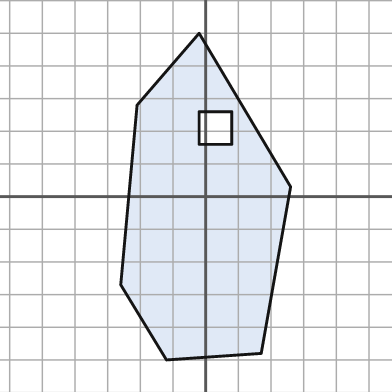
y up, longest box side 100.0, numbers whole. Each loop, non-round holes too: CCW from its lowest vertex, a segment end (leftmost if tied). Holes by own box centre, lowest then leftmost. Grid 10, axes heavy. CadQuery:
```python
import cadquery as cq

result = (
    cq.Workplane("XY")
    .moveTo(-12.0, -50.0)
    .lineTo(17.0, -48.0)
    .lineTo(26.0, 3.0)
    .lineTo(-2.0, 50.0)
    .lineTo(-21.0, 28.0)
    .lineTo(-26.0, -27.0)
    .close()
    .moveTo(-2.0, 16.0)
    .lineTo(8.0, 16.0)
    .lineTo(8.0, 26.0)
    .lineTo(-2.0, 26.0)
    .close()
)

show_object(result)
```